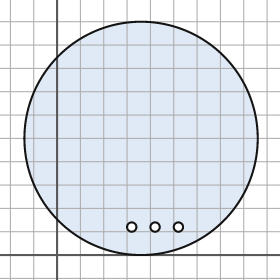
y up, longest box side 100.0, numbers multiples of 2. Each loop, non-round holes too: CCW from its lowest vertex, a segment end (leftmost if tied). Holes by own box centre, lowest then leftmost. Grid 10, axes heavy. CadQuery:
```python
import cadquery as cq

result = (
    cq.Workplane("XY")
    .moveTo(36.0, 50.0)
    .circle(50.0)
    .moveTo(32.0, 12.0)
    .circle(2.0)
    .moveTo(42.0, 12.0)
    .circle(2.0)
    .moveTo(52.0, 12.0)
    .circle(2.0)
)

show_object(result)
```